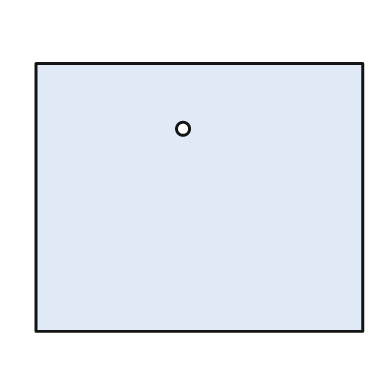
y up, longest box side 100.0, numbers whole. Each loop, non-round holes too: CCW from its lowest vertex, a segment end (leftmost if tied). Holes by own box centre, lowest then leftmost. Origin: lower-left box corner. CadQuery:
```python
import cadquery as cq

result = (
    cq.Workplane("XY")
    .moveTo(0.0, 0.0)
    .lineTo(100.0, 0.0)
    .lineTo(100.0, 82.0)
    .lineTo(0.0, 82.0)
    .close()
    .moveTo(45.0, 62.0)
    .circle(2.0)
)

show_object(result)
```